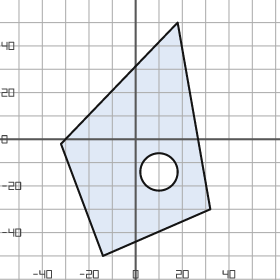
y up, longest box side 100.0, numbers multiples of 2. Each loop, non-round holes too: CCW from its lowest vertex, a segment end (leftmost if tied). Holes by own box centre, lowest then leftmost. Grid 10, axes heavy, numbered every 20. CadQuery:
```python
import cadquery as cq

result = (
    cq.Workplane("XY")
    .moveTo(-14.0, -50.0)
    .lineTo(32.0, -30.0)
    .lineTo(18.0, 50.0)
    .lineTo(-32.0, -2.0)
    .close()
    .moveTo(10.0, -14.0)
    .circle(8.0)
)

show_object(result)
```